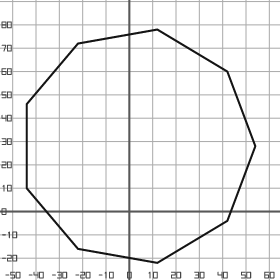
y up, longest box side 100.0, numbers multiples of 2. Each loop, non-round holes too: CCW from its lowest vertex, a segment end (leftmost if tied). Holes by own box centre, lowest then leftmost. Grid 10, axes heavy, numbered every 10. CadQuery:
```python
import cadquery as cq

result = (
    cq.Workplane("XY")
    .moveTo(12.0, -22.0)
    .lineTo(42.0, -4.0)
    .lineTo(54.0, 28.0)
    .lineTo(42.0, 60.0)
    .lineTo(12.0, 78.0)
    .lineTo(-22.0, 72.0)
    .lineTo(-44.0, 46.0)
    .lineTo(-44.0, 10.0)
    .lineTo(-22.0, -16.0)
    .close()
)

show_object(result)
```